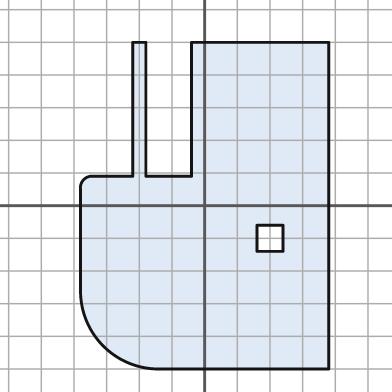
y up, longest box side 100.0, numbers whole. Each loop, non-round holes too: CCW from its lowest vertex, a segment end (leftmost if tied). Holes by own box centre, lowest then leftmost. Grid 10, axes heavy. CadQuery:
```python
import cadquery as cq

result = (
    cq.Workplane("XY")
    .moveTo(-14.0, -50.0)
    .lineTo(38.0, -50.0)
    .lineTo(38.0, 50.0)
    .lineTo(-4.0, 50.0)
    .lineTo(-4.0, 9.0)
    .lineTo(-18.0, 9.0)
    .lineTo(-18.0, 50.0)
    .lineTo(-22.0, 50.0)
    .lineTo(-22.0, 9.0)
    .lineTo(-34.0, 9.0)
    .threePointArc((-37.0, 8.0), (-38.0, 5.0))
    .lineTo(-38.0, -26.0)
    .threePointArc((-31.0, -43.0), (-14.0, -50.0))
    .close()
    .moveTo(16.0, -14.0)
    .lineTo(24.0, -14.0)
    .lineTo(24.0, -6.0)
    .lineTo(16.0, -6.0)
    .close()
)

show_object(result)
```